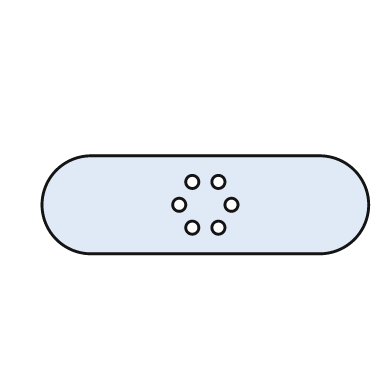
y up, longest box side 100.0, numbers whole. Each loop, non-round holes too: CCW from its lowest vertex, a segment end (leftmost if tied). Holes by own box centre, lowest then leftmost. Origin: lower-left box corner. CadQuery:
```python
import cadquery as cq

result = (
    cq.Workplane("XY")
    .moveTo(15.0, 0.0)
    .lineTo(85.0, 0.0)
    .threePointArc((100.0, 15.0), (85.0, 30.0))
    .lineTo(15.0, 30.0)
    .threePointArc((0.0, 15.0), (15.0, 0.0))
    .close()
    .moveTo(46.0, 8.0)
    .circle(2.0)
    .moveTo(54.0, 8.0)
    .circle(2.0)
    .moveTo(42.0, 15.0)
    .circle(2.0)
    .moveTo(58.0, 15.0)
    .circle(2.0)
    .moveTo(46.0, 22.0)
    .circle(2.0)
    .moveTo(54.0, 22.0)
    .circle(2.0)
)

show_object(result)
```